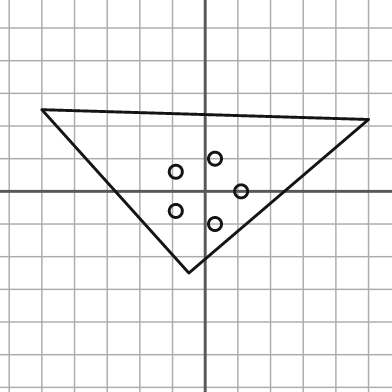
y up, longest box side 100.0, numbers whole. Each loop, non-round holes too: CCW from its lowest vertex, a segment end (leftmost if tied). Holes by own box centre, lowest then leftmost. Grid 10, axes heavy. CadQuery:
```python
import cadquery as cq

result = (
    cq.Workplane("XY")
    .moveTo(-5.0, -25.0)
    .lineTo(50.0, 22.0)
    .lineTo(-50.0, 25.0)
    .close()
    .moveTo(3.0, -10.0)
    .circle(2.0)
    .moveTo(-9.0, -6.0)
    .circle(2.0)
    .moveTo(11.0, 0.0)
    .circle(2.0)
    .moveTo(-9.0, 6.0)
    .circle(2.0)
    .moveTo(3.0, 10.0)
    .circle(2.0)
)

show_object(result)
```